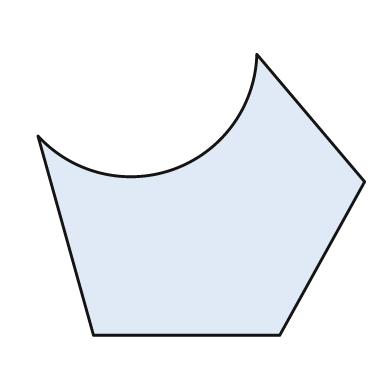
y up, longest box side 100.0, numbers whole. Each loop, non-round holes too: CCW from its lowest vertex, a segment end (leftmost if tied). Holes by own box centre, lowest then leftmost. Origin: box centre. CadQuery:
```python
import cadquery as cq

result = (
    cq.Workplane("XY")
    .moveTo(-33.0, -43.0)
    .lineTo(24.0, -43.0)
    .lineTo(50.0, 4.0)
    .lineTo(17.0, 43.0)
    .threePointArc((-8.0, 8.0), (-50.0, 18.0))
    .close()
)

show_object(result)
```